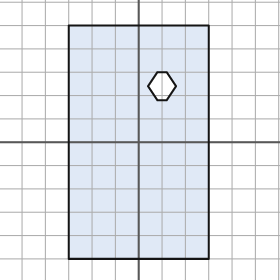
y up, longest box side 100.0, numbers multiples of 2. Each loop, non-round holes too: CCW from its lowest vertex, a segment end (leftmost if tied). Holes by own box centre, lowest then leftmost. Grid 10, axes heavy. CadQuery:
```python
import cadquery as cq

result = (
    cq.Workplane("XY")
    .moveTo(-30.0, -50.0)
    .lineTo(30.0, -50.0)
    .lineTo(30.0, 50.0)
    .lineTo(-30.0, 50.0)
    .close()
    .moveTo(8.0, 18.0)
    .lineTo(12.0, 18.0)
    .lineTo(16.0, 24.0)
    .lineTo(12.0, 30.0)
    .lineTo(8.0, 30.0)
    .lineTo(4.0, 24.0)
    .close()
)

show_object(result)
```